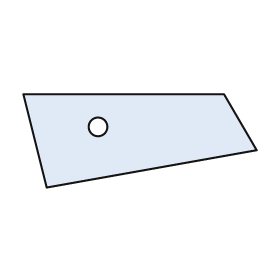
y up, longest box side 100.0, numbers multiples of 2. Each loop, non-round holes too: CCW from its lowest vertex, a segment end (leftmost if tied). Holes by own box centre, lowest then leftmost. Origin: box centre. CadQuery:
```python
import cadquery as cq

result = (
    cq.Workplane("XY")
    .moveTo(-40.0, -20.0)
    .lineTo(50.0, -4.0)
    .lineTo(36.0, 20.0)
    .lineTo(-50.0, 20.0)
    .close()
    .moveTo(-18.0, 6.0)
    .circle(4.0)
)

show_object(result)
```